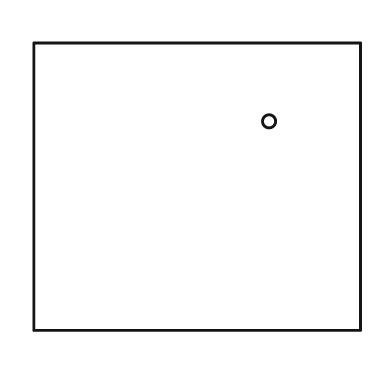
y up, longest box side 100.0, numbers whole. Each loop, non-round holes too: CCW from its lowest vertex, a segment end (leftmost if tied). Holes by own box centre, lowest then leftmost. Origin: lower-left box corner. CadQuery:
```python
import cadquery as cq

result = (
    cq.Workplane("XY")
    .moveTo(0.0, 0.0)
    .lineTo(100.0, 0.0)
    .lineTo(100.0, 88.0)
    .lineTo(0.0, 88.0)
    .close()
    .moveTo(72.0, 64.0)
    .circle(2.0)
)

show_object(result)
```